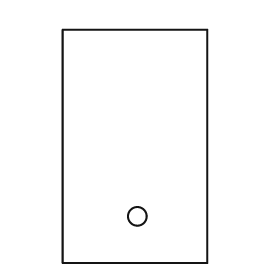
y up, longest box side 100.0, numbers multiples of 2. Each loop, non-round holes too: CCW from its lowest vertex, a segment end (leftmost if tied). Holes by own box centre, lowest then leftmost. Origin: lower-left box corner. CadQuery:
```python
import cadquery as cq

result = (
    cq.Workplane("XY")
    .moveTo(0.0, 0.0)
    .lineTo(62.0, 0.0)
    .lineTo(62.0, 100.0)
    .lineTo(0.0, 100.0)
    .close()
    .moveTo(32.0, 20.0)
    .circle(4.0)
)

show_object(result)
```